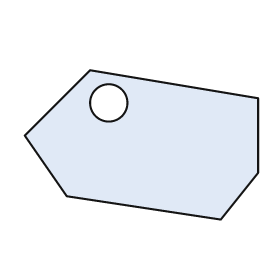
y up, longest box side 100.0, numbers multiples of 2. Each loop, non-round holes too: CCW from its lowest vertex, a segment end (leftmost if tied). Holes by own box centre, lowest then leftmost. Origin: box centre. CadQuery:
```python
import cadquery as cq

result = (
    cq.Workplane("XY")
    .moveTo(34.0, -32.0)
    .lineTo(50.0, -12.0)
    .lineTo(50.0, 20.0)
    .lineTo(-22.0, 32.0)
    .lineTo(-50.0, 4.0)
    .lineTo(-32.0, -22.0)
    .close()
    .moveTo(-14.0, 18.0)
    .circle(8.0)
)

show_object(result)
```